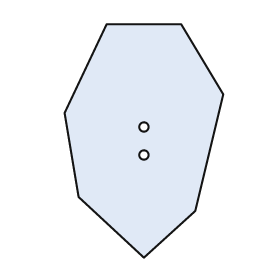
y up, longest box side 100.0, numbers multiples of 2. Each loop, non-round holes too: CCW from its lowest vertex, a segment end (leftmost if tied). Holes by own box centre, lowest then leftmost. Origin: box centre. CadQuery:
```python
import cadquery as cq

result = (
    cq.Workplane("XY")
    .moveTo(0.0, -50.0)
    .lineTo(22.0, -30.0)
    .lineTo(34.0, 20.0)
    .lineTo(16.0, 50.0)
    .lineTo(-16.0, 50.0)
    .lineTo(-34.0, 12.0)
    .lineTo(-28.0, -24.0)
    .close()
    .moveTo(0.0, -6.0)
    .circle(2.0)
    .moveTo(0.0, 6.0)
    .circle(2.0)
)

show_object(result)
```